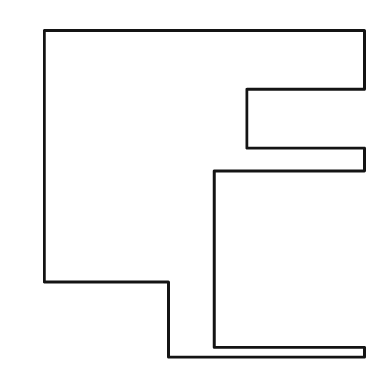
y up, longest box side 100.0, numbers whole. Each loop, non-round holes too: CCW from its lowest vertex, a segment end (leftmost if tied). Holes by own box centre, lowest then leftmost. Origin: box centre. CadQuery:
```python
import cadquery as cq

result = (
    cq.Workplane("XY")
    .moveTo(-11.0, -50.0)
    .lineTo(49.0, -50.0)
    .lineTo(49.0, -47.0)
    .lineTo(3.0, -47.0)
    .lineTo(3.0, 7.0)
    .lineTo(49.0, 7.0)
    .lineTo(49.0, 14.0)
    .lineTo(13.0, 14.0)
    .lineTo(13.0, 32.0)
    .lineTo(49.0, 32.0)
    .lineTo(49.0, 50.0)
    .lineTo(-49.0, 50.0)
    .lineTo(-49.0, -27.0)
    .lineTo(-11.0, -27.0)
    .close()
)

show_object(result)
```